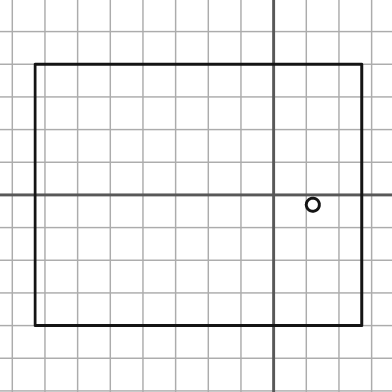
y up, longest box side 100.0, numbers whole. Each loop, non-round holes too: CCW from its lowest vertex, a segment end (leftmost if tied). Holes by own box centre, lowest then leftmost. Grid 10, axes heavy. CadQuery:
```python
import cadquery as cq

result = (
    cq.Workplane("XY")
    .moveTo(-73.0, -40.0)
    .lineTo(27.0, -40.0)
    .lineTo(27.0, 40.0)
    .lineTo(-73.0, 40.0)
    .close()
    .moveTo(12.0, -3.0)
    .circle(2.0)
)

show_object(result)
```